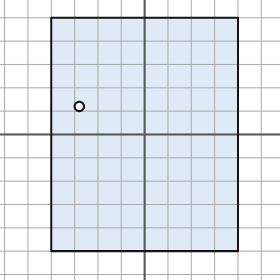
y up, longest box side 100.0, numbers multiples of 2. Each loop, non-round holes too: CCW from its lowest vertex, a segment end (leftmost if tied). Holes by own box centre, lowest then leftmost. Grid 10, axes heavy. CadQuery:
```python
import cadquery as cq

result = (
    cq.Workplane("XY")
    .moveTo(-40.0, -50.0)
    .lineTo(40.0, -50.0)
    .lineTo(40.0, 50.0)
    .lineTo(-40.0, 50.0)
    .close()
    .moveTo(-28.0, 12.0)
    .circle(2.0)
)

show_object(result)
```